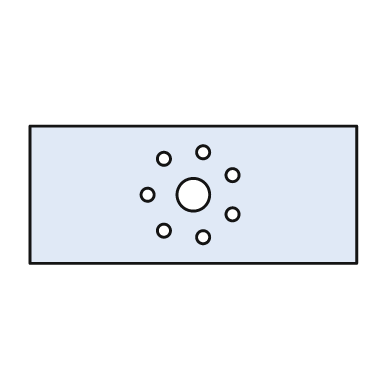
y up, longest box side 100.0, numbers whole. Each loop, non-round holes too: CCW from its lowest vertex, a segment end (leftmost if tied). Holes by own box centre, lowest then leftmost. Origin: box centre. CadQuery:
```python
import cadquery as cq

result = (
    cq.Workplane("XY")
    .moveTo(-50.0, -21.0)
    .lineTo(50.0, -21.0)
    .lineTo(50.0, 21.0)
    .lineTo(-50.0, 21.0)
    .close()
    .moveTo(3.0, -13.0)
    .circle(2.0)
    .moveTo(-9.0, -11.0)
    .circle(2.0)
    .moveTo(12.0, -6.0)
    .circle(2.0)
    .moveTo(-14.0, 0.0)
    .circle(2.0)
    .moveTo(0.0, 0.0)
    .circle(5.0)
    .moveTo(12.0, 6.0)
    .circle(2.0)
    .moveTo(-9.0, 11.0)
    .circle(2.0)
    .moveTo(3.0, 13.0)
    .circle(2.0)
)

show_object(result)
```